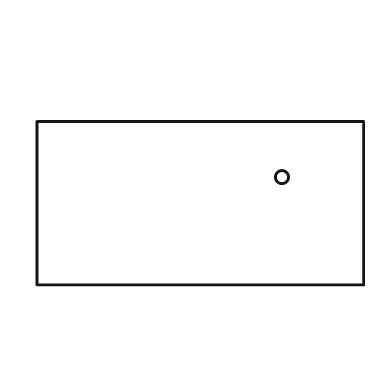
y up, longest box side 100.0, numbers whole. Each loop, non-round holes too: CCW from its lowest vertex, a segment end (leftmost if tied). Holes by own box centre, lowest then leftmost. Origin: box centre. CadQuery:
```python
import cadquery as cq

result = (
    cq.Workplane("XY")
    .moveTo(-50.0, -25.0)
    .lineTo(50.0, -25.0)
    .lineTo(50.0, 25.0)
    .lineTo(-50.0, 25.0)
    .close()
    .moveTo(25.0, 8.0)
    .circle(2.0)
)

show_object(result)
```